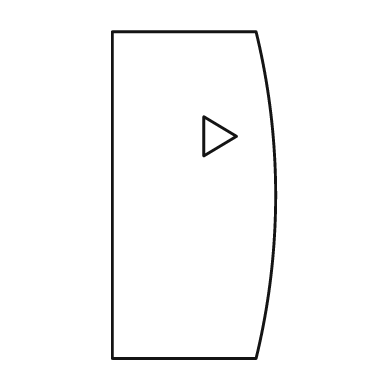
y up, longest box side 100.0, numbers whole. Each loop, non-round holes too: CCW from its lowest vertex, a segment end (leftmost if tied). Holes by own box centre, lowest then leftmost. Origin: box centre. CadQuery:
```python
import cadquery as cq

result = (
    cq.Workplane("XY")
    .moveTo(-25.0, -50.0)
    .lineTo(19.0, -50.0)
    .threePointArc((25.0, 0.0), (19.0, 50.0))
    .lineTo(-25.0, 50.0)
    .close()
    .moveTo(3.0, 12.0)
    .lineTo(13.0, 18.0)
    .lineTo(3.0, 24.0)
    .close()
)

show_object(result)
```